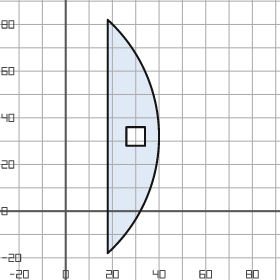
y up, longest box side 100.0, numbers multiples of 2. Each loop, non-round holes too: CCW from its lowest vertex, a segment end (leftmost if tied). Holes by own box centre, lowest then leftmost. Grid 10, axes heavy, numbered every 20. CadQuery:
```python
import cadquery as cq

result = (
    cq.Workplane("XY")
    .moveTo(18.0, -18.0)
    .threePointArc((40.0, 32.0), (18.0, 82.0))
    .close()
    .moveTo(26.0, 28.0)
    .lineTo(34.0, 28.0)
    .lineTo(34.0, 36.0)
    .lineTo(26.0, 36.0)
    .close()
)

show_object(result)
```